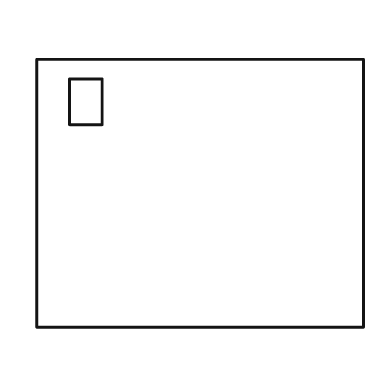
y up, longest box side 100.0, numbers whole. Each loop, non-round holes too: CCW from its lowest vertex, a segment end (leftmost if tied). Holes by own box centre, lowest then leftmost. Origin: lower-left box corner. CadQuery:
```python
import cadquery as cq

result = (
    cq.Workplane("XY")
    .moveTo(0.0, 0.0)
    .lineTo(100.0, 0.0)
    .lineTo(100.0, 82.0)
    .lineTo(0.0, 82.0)
    .close()
    .moveTo(10.0, 62.0)
    .lineTo(20.0, 62.0)
    .lineTo(20.0, 76.0)
    .lineTo(10.0, 76.0)
    .close()
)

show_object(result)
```